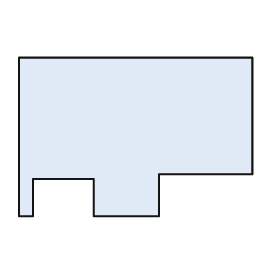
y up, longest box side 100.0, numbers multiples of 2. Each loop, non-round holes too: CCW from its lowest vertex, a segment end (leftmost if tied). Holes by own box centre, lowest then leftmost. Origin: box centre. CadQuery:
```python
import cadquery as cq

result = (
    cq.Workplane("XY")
    .moveTo(-50.0, -34.0)
    .lineTo(-44.0, -34.0)
    .lineTo(-44.0, -18.0)
    .lineTo(-18.0, -18.0)
    .lineTo(-18.0, -34.0)
    .lineTo(10.0, -34.0)
    .lineTo(10.0, -16.0)
    .lineTo(50.0, -16.0)
    .lineTo(50.0, 34.0)
    .lineTo(-50.0, 34.0)
    .close()
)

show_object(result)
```